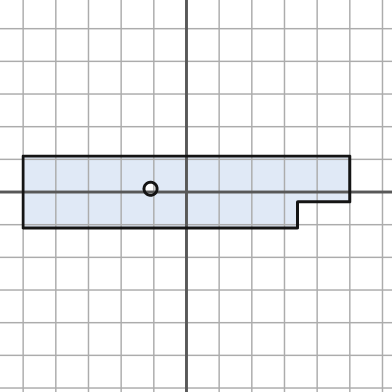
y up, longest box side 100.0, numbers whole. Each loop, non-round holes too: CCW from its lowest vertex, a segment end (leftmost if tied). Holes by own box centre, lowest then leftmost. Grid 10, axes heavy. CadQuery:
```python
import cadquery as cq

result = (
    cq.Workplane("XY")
    .moveTo(-50.0, -11.0)
    .lineTo(34.0, -11.0)
    .lineTo(34.0, -3.0)
    .lineTo(50.0, -3.0)
    .lineTo(50.0, 11.0)
    .lineTo(-50.0, 11.0)
    .close()
    .moveTo(-11.0, 1.0)
    .circle(2.0)
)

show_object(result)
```